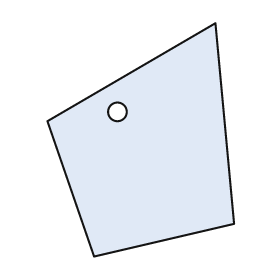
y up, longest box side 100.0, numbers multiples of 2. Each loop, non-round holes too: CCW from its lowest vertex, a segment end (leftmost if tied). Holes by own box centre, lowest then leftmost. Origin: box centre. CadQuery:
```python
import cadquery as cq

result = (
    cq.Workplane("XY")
    .moveTo(-20.0, -50.0)
    .lineTo(40.0, -36.0)
    .lineTo(32.0, 50.0)
    .lineTo(-40.0, 8.0)
    .close()
    .moveTo(-10.0, 12.0)
    .circle(4.0)
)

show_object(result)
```